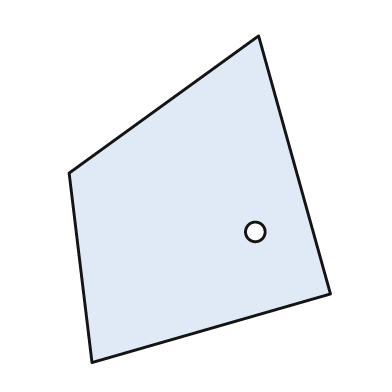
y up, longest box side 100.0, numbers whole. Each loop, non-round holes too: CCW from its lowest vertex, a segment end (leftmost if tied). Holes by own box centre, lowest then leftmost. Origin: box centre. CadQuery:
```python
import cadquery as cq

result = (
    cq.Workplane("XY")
    .moveTo(-33.0, -50.0)
    .lineTo(40.0, -29.0)
    .lineTo(18.0, 50.0)
    .lineTo(-40.0, 8.0)
    .close()
    .moveTo(17.0, -10.0)
    .circle(3.0)
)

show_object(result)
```